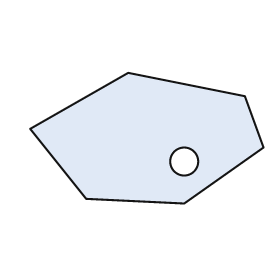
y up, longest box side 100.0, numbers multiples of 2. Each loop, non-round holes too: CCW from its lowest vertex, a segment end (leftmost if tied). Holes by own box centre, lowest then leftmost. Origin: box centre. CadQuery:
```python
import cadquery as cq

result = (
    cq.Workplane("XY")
    .moveTo(16.0, -28.0)
    .lineTo(50.0, -4.0)
    .lineTo(42.0, 18.0)
    .lineTo(-8.0, 28.0)
    .lineTo(-50.0, 4.0)
    .lineTo(-26.0, -26.0)
    .close()
    .moveTo(16.0, -10.0)
    .circle(6.0)
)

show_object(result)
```